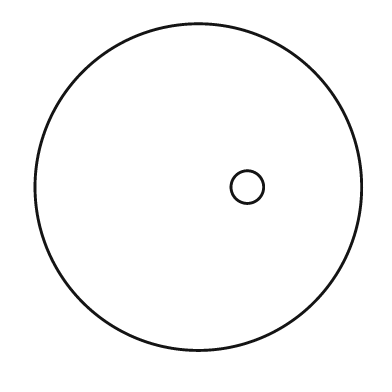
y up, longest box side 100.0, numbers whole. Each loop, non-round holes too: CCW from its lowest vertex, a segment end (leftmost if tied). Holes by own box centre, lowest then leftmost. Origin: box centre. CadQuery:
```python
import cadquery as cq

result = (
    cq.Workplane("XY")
    .moveTo(0.0, 0.0)
    .circle(50.0)
    .moveTo(15.0, 0.0)
    .circle(5.0)
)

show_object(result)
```